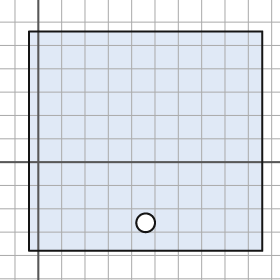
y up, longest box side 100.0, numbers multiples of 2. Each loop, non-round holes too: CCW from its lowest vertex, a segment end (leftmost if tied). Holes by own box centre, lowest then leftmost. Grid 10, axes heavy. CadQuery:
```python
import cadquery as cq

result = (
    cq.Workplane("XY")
    .moveTo(-4.0, -38.0)
    .lineTo(96.0, -38.0)
    .lineTo(96.0, 56.0)
    .lineTo(-4.0, 56.0)
    .close()
    .moveTo(46.0, -26.0)
    .circle(4.0)
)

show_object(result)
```